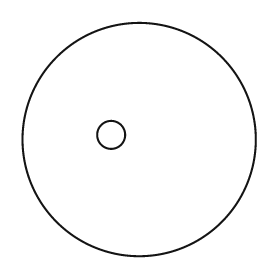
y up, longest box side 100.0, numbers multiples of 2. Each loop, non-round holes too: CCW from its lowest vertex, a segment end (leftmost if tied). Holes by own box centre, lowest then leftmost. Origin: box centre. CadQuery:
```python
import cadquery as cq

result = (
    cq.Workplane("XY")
    .moveTo(0.0, 0.0)
    .circle(50.0)
    .moveTo(-12.0, 2.0)
    .circle(6.0)
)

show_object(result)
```